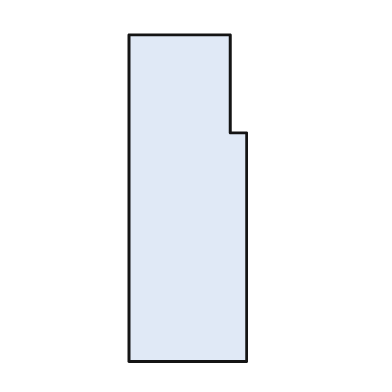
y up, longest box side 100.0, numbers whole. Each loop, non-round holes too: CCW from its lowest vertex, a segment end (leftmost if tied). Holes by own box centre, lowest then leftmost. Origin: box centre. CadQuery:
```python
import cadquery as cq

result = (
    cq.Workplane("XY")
    .moveTo(-18.0, -50.0)
    .lineTo(18.0, -50.0)
    .lineTo(18.0, 20.0)
    .lineTo(13.0, 20.0)
    .lineTo(13.0, 50.0)
    .lineTo(-18.0, 50.0)
    .close()
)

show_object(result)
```